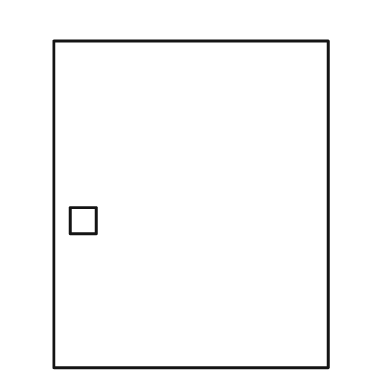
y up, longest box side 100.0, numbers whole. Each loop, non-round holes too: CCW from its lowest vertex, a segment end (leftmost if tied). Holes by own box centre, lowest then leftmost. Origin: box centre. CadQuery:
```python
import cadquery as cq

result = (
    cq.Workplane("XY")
    .moveTo(-42.0, -50.0)
    .lineTo(42.0, -50.0)
    .lineTo(42.0, 50.0)
    .lineTo(-42.0, 50.0)
    .close()
    .moveTo(-37.0, -9.0)
    .lineTo(-29.0, -9.0)
    .lineTo(-29.0, -1.0)
    .lineTo(-37.0, -1.0)
    .close()
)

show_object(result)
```